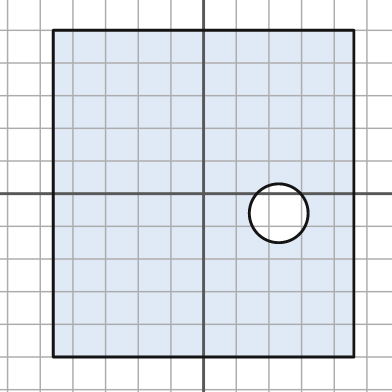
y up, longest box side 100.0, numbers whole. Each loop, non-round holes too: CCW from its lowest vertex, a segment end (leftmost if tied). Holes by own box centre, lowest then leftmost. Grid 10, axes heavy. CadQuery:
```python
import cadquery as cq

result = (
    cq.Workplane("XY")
    .moveTo(-46.0, -50.0)
    .lineTo(46.0, -50.0)
    .lineTo(46.0, 50.0)
    .lineTo(-46.0, 50.0)
    .close()
    .moveTo(23.0, -6.0)
    .circle(9.0)
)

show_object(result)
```